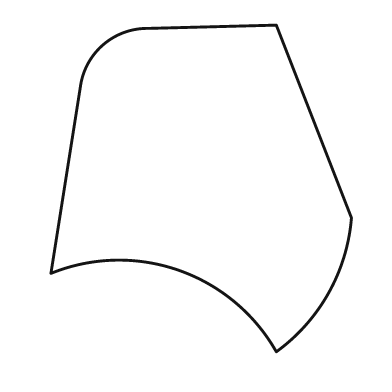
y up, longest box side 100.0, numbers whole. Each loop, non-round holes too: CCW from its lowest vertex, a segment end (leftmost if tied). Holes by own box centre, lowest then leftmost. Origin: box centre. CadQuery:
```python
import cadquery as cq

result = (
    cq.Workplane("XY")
    .moveTo(23.0, -50.0)
    .threePointArc((39.0, -32.0), (46.0, -9.0))
    .lineTo(23.0, 50.0)
    .lineTo(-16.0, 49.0)
    .threePointArc((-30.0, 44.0), (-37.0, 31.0))
    .lineTo(-46.0, -26.0)
    .threePointArc((-7.0, -25.0), (23.0, -50.0))
    .close()
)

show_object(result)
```